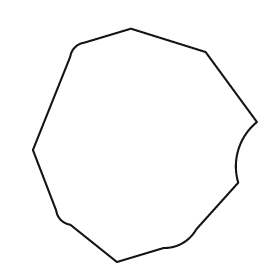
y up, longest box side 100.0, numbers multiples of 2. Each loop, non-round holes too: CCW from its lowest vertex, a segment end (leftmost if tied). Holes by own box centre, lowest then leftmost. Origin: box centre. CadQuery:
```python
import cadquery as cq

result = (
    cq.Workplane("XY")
    .moveTo(-12.0, -50.0)
    .lineTo(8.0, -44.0)
    .threePointArc((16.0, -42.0), (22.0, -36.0))
    .lineTo(40.0, -16.0)
    .threePointArc((40.0, -2.0), (48.0, 10.0))
    .lineTo(26.0, 40.0)
    .lineTo(-6.0, 50.0)
    .lineTo(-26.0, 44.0)
    .threePointArc((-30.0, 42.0), (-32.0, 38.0))
    .lineTo(-48.0, -2.0)
    .lineTo(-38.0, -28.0)
    .threePointArc((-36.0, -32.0), (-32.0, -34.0))
    .close()
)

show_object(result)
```